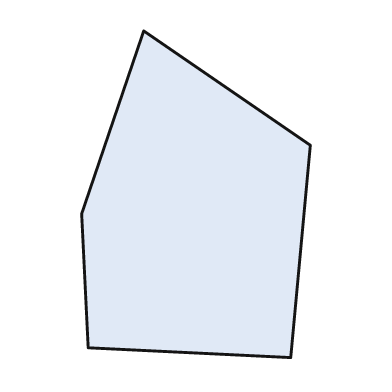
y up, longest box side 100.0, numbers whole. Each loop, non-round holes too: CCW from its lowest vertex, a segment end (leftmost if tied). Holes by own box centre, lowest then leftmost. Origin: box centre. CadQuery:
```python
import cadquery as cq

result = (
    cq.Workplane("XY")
    .moveTo(29.0, -50.0)
    .lineTo(35.0, 15.0)
    .lineTo(-16.0, 50.0)
    .lineTo(-35.0, -6.0)
    .lineTo(-33.0, -47.0)
    .close()
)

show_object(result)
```